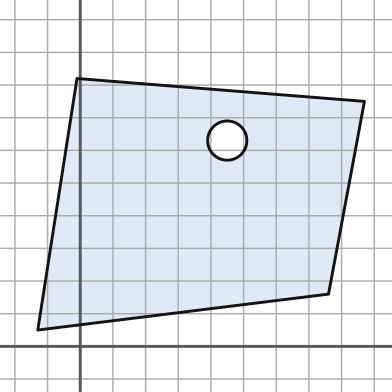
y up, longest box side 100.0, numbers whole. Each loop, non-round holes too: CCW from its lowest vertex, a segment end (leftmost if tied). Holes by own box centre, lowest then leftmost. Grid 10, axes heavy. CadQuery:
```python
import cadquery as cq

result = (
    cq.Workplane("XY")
    .moveTo(-13.0, 5.0)
    .lineTo(76.0, 16.0)
    .lineTo(87.0, 75.0)
    .lineTo(-1.0, 82.0)
    .close()
    .moveTo(45.0, 63.0)
    .circle(6.0)
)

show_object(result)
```